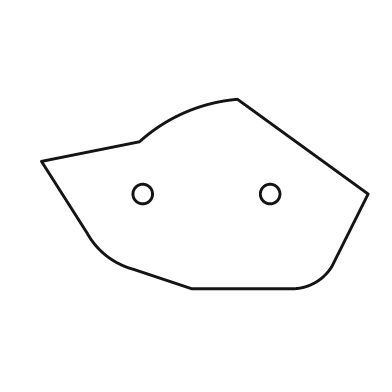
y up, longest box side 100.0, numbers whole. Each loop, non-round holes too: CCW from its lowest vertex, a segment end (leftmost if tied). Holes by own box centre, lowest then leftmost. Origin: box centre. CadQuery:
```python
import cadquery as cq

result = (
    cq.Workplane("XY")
    .moveTo(-4.0, -29.0)
    .lineTo(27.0, -29.0)
    .threePointArc((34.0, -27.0), (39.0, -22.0))
    .lineTo(50.0, 0.0)
    .lineTo(10.0, 29.0)
    .threePointArc((-6.0, 25.0), (-20.0, 16.0))
    .lineTo(-50.0, 10.0)
    .lineTo(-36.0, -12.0)
    .threePointArc((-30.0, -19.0), (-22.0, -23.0))
    .close()
    .moveTo(-19.0, 0.0)
    .circle(3.0)
    .moveTo(20.0, 0.0)
    .circle(3.0)
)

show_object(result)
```